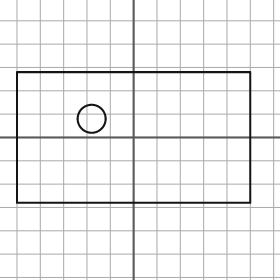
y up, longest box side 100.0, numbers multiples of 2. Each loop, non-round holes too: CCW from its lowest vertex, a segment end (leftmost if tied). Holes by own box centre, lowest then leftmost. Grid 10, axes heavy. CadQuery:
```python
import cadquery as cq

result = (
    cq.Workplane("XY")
    .moveTo(-50.0, -28.0)
    .lineTo(50.0, -28.0)
    .lineTo(50.0, 28.0)
    .lineTo(-50.0, 28.0)
    .close()
    .moveTo(-18.0, 8.0)
    .circle(6.0)
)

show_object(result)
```